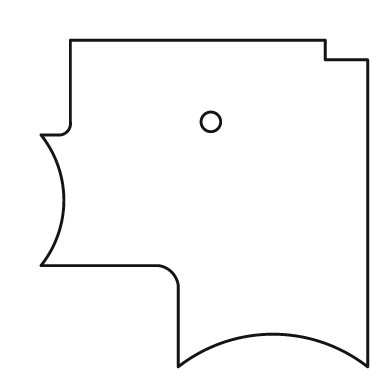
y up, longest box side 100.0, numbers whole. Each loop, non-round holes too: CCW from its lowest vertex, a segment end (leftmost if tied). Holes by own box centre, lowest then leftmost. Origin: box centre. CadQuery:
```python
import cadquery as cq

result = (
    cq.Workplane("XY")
    .moveTo(-8.0, -50.0)
    .threePointArc((21.0, -40.0), (50.0, -50.0))
    .lineTo(50.0, 44.0)
    .lineTo(37.0, 44.0)
    .lineTo(37.0, 50.0)
    .lineTo(-41.0, 50.0)
    .lineTo(-41.0, 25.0)
    .threePointArc((-42.0, 22.0), (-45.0, 21.0))
    .lineTo(-50.0, 21.0)
    .threePointArc((-43.0, 1.0), (-50.0, -19.0))
    .lineTo(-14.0, -19.0)
    .threePointArc((-10.0, -21.0), (-8.0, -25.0))
    .close()
    .moveTo(2.0, 25.0)
    .circle(3.0)
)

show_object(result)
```